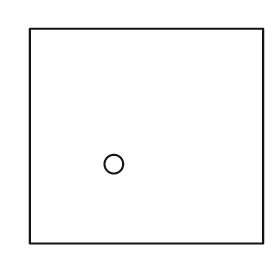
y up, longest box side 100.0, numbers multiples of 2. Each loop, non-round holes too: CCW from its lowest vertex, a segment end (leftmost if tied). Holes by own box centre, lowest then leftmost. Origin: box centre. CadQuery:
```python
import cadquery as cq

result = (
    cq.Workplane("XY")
    .moveTo(-50.0, -46.0)
    .lineTo(50.0, -46.0)
    .lineTo(50.0, 46.0)
    .lineTo(-50.0, 46.0)
    .close()
    .moveTo(-14.0, -12.0)
    .circle(4.0)
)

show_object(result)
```